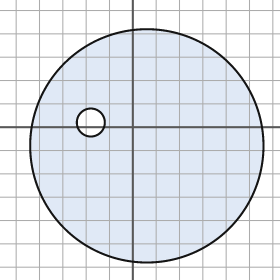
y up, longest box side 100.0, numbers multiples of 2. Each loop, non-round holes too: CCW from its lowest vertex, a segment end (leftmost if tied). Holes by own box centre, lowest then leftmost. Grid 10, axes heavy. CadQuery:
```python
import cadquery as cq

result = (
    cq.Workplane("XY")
    .moveTo(6.0, -8.0)
    .circle(50.0)
    .moveTo(-18.0, 2.0)
    .circle(6.0)
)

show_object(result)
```